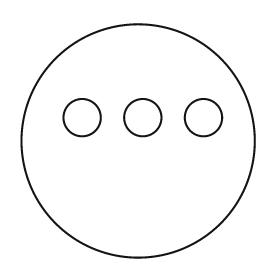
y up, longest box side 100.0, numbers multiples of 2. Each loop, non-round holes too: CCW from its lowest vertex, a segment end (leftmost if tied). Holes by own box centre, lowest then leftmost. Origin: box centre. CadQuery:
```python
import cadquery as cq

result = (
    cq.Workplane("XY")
    .moveTo(0.0, 0.0)
    .circle(50.0)
    .moveTo(-24.0, 10.0)
    .circle(8.0)
    .moveTo(2.0, 10.0)
    .circle(8.0)
    .moveTo(28.0, 10.0)
    .circle(8.0)
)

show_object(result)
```